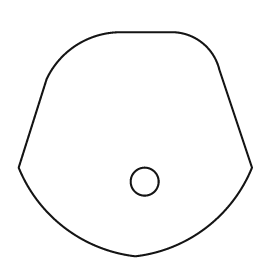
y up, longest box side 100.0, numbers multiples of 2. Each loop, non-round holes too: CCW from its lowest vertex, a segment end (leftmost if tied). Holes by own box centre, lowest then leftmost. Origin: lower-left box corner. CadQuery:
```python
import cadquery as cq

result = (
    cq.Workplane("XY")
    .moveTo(50.0, 0.0)
    .threePointArc((80.0, 12.0), (100.0, 38.0))
    .lineTo(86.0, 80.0)
    .threePointArc((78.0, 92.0), (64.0, 96.0))
    .lineTo(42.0, 96.0)
    .threePointArc((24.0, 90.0), (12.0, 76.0))
    .lineTo(0.0, 38.0)
    .threePointArc((20.0, 12.0), (50.0, 0.0))
    .close()
    .moveTo(54.0, 32.0)
    .circle(6.0)
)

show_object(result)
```